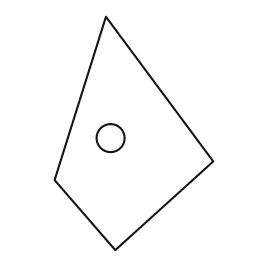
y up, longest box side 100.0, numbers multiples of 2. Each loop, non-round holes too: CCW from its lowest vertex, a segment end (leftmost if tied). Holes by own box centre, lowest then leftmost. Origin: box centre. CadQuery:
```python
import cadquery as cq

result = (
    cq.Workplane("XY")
    .moveTo(-8.0, -50.0)
    .lineTo(34.0, -12.0)
    .lineTo(-12.0, 50.0)
    .lineTo(-34.0, -20.0)
    .close()
    .moveTo(-10.0, -2.0)
    .circle(6.0)
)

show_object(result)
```